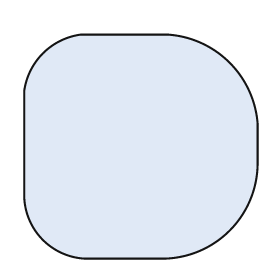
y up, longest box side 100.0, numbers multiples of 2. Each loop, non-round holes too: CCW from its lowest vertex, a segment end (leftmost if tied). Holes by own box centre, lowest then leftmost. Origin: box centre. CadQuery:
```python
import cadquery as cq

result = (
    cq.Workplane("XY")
    .moveTo(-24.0, -48.0)
    .lineTo(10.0, -48.0)
    .threePointArc((38.0, -36.0), (50.0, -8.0))
    .lineTo(50.0, 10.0)
    .threePointArc((38.0, 36.0), (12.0, 48.0))
    .lineTo(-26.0, 48.0)
    .threePointArc((-42.0, 40.0), (-50.0, 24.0))
    .lineTo(-50.0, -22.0)
    .threePointArc((-42.0, -40.0), (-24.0, -48.0))
    .close()
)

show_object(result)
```